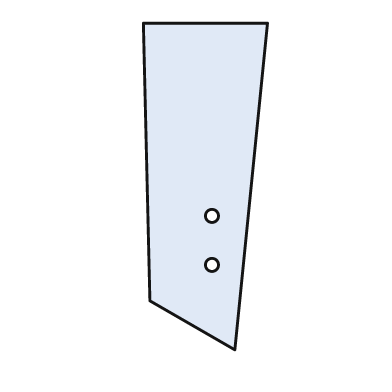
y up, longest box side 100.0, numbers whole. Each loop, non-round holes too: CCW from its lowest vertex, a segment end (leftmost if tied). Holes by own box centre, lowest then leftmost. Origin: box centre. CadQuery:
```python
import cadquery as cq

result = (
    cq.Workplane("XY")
    .moveTo(9.0, -50.0)
    .lineTo(19.0, 50.0)
    .lineTo(-19.0, 50.0)
    .lineTo(-17.0, -35.0)
    .close()
    .moveTo(2.0, -24.0)
    .circle(2.0)
    .moveTo(2.0, -9.0)
    .circle(2.0)
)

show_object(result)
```